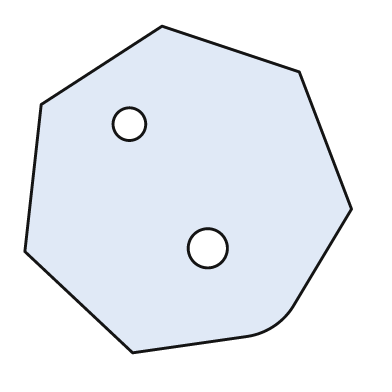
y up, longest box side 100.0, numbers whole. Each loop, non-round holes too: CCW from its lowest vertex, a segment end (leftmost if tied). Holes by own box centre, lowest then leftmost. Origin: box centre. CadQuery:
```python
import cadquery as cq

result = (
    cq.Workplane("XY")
    .moveTo(-17.0, -50.0)
    .lineTo(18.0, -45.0)
    .threePointArc((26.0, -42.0), (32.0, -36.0))
    .lineTo(50.0, -6.0)
    .lineTo(34.0, 36.0)
    .lineTo(-8.0, 50.0)
    .lineTo(-45.0, 26.0)
    .lineTo(-50.0, -19.0)
    .close()
    .moveTo(6.0, -18.0)
    .circle(6.0)
    .moveTo(-18.0, 20.0)
    .circle(5.0)
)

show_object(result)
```